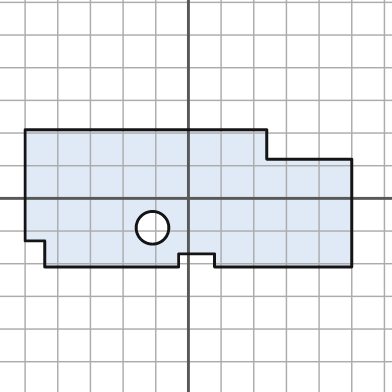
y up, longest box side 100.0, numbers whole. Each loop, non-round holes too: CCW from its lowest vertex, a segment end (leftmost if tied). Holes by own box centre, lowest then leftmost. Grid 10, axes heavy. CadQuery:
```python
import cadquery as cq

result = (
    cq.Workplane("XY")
    .moveTo(-44.0, -21.0)
    .lineTo(-3.0, -21.0)
    .lineTo(-3.0, -17.0)
    .lineTo(8.0, -17.0)
    .lineTo(8.0, -21.0)
    .lineTo(50.0, -21.0)
    .lineTo(50.0, 12.0)
    .lineTo(24.0, 12.0)
    .lineTo(24.0, 21.0)
    .lineTo(-50.0, 21.0)
    .lineTo(-50.0, -13.0)
    .lineTo(-44.0, -13.0)
    .close()
    .moveTo(-11.0, -9.0)
    .circle(5.0)
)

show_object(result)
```